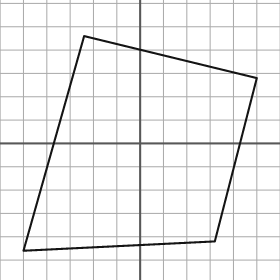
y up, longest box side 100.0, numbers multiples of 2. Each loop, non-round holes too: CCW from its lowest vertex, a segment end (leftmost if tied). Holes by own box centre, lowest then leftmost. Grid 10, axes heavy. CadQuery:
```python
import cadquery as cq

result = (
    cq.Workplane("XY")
    .moveTo(-50.0, -46.0)
    .lineTo(32.0, -42.0)
    .lineTo(50.0, 28.0)
    .lineTo(-24.0, 46.0)
    .close()
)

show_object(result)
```